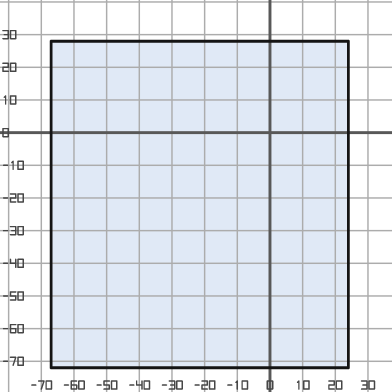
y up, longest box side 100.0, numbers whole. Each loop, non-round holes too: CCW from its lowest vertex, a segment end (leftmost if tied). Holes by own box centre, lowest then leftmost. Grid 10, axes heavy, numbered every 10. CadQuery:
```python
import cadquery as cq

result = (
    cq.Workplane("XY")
    .moveTo(-67.0, -72.0)
    .lineTo(24.0, -72.0)
    .lineTo(24.0, 28.0)
    .lineTo(-67.0, 28.0)
    .close()
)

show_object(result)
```